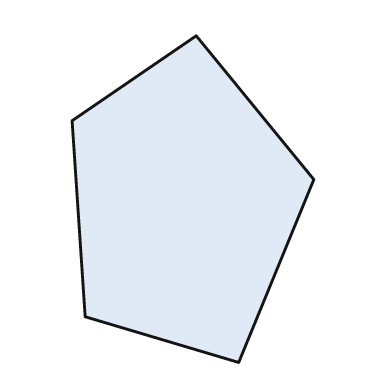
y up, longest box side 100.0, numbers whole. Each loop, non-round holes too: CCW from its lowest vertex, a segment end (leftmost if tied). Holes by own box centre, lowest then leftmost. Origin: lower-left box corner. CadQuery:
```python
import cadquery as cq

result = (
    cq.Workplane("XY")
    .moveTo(51.0, 0.0)
    .lineTo(74.0, 56.0)
    .lineTo(38.0, 100.0)
    .lineTo(0.0, 74.0)
    .lineTo(4.0, 14.0)
    .close()
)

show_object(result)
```